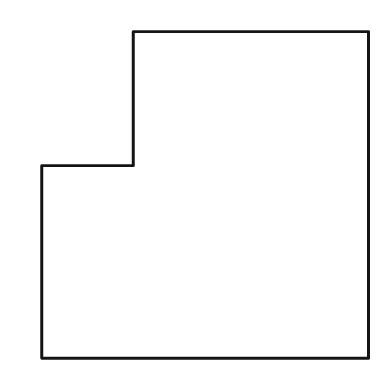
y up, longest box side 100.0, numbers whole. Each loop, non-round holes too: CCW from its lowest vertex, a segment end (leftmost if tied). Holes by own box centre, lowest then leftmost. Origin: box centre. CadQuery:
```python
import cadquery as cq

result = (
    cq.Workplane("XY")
    .moveTo(-50.0, -50.0)
    .lineTo(50.0, -50.0)
    .lineTo(50.0, 50.0)
    .lineTo(-22.0, 50.0)
    .lineTo(-22.0, 9.0)
    .lineTo(-50.0, 9.0)
    .close()
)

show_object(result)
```